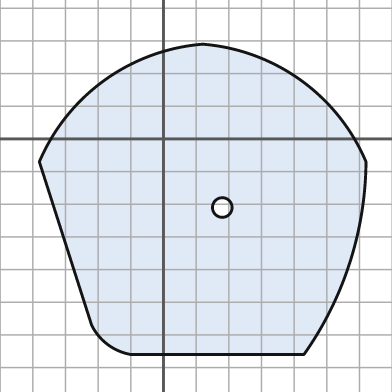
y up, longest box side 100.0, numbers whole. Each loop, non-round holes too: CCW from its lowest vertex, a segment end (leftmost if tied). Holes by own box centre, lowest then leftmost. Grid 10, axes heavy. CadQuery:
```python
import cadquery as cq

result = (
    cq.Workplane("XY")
    .moveTo(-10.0, -66.0)
    .lineTo(43.0, -66.0)
    .threePointArc((57.0, -38.0), (62.0, -7.0))
    .threePointArc((42.0, 18.0), (12.0, 29.0))
    .threePointArc((-18.0, 18.0), (-38.0, -7.0))
    .lineTo(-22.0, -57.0)
    .threePointArc((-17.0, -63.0), (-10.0, -66.0))
    .close()
    .moveTo(18.0, -21.0)
    .circle(3.0)
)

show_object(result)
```